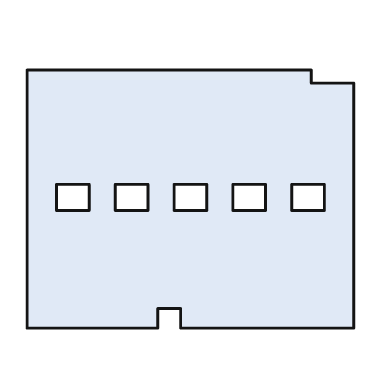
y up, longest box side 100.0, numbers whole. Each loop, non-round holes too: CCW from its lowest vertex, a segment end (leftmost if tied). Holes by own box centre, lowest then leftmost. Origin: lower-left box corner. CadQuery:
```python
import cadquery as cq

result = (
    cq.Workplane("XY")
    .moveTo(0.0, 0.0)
    .lineTo(40.0, 0.0)
    .lineTo(40.0, 6.0)
    .lineTo(47.0, 6.0)
    .lineTo(47.0, 0.0)
    .lineTo(100.0, 0.0)
    .lineTo(100.0, 75.0)
    .lineTo(87.0, 75.0)
    .lineTo(87.0, 79.0)
    .lineTo(0.0, 79.0)
    .close()
    .moveTo(9.0, 36.0)
    .lineTo(19.0, 36.0)
    .lineTo(19.0, 44.0)
    .lineTo(9.0, 44.0)
    .close()
    .moveTo(27.0, 36.0)
    .lineTo(37.0, 36.0)
    .lineTo(37.0, 44.0)
    .lineTo(27.0, 44.0)
    .close()
    .moveTo(45.0, 36.0)
    .lineTo(55.0, 36.0)
    .lineTo(55.0, 44.0)
    .lineTo(45.0, 44.0)
    .close()
    .moveTo(63.0, 36.0)
    .lineTo(73.0, 36.0)
    .lineTo(73.0, 44.0)
    .lineTo(63.0, 44.0)
    .close()
    .moveTo(81.0, 36.0)
    .lineTo(91.0, 36.0)
    .lineTo(91.0, 44.0)
    .lineTo(81.0, 44.0)
    .close()
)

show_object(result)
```